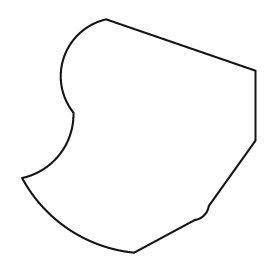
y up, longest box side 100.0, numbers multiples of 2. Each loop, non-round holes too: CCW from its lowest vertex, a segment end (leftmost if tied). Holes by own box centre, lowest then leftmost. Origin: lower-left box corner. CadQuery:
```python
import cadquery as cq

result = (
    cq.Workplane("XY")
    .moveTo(48.0, 0.0)
    .lineTo(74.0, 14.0)
    .threePointArc((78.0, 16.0), (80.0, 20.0))
    .lineTo(100.0, 48.0)
    .lineTo(100.0, 78.0)
    .lineTo(36.0, 100.0)
    .threePointArc((18.0, 84.0), (22.0, 60.0))
    .threePointArc((16.0, 42.0), (0.0, 32.0))
    .threePointArc((20.0, 10.0), (48.0, 0.0))
    .close()
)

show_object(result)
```